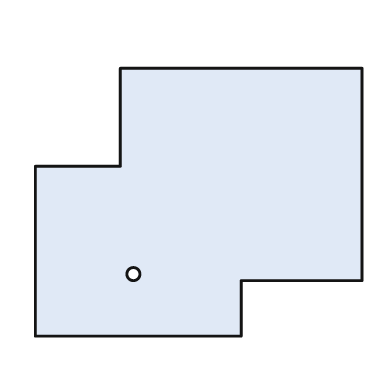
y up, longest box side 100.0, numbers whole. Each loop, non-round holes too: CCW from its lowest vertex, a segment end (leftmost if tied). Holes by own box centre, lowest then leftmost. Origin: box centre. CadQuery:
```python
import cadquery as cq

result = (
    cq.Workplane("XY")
    .moveTo(-50.0, -41.0)
    .lineTo(13.0, -41.0)
    .lineTo(13.0, -24.0)
    .lineTo(50.0, -24.0)
    .lineTo(50.0, 41.0)
    .lineTo(-24.0, 41.0)
    .lineTo(-24.0, 11.0)
    .lineTo(-50.0, 11.0)
    .close()
    .moveTo(-20.0, -22.0)
    .circle(2.0)
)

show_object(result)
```